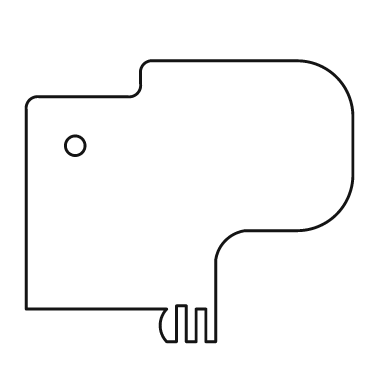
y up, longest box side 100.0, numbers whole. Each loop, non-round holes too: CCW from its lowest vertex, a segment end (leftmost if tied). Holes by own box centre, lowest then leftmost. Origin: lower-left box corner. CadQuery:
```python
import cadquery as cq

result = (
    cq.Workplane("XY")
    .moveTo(43.0, 0.0)
    .lineTo(46.0, 0.0)
    .lineTo(46.0, 11.0)
    .lineTo(49.0, 11.0)
    .lineTo(49.0, 0.0)
    .lineTo(52.0, 0.0)
    .lineTo(52.0, 10.0)
    .lineTo(55.0, 10.0)
    .lineTo(55.0, 0.0)
    .lineTo(58.0, 0.0)
    .lineTo(58.0, 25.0)
    .threePointArc((61.0, 31.0), (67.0, 34.0))
    .lineTo(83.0, 34.0)
    .threePointArc((95.0, 39.0), (100.0, 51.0))
    .lineTo(100.0, 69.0)
    .threePointArc((95.0, 81.0), (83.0, 86.0))
    .lineTo(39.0, 86.0)
    .threePointArc((36.0, 85.0), (35.0, 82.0))
    .lineTo(35.0, 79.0)
    .threePointArc((34.0, 76.0), (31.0, 75.0))
    .lineTo(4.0, 75.0)
    .threePointArc((1.0, 74.0), (0.0, 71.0))
    .lineTo(0.0, 10.0)
    .lineTo(43.0, 10.0)
    .threePointArc((41.0, 5.0), (43.0, 0.0))
    .close()
    .moveTo(15.0, 60.0)
    .circle(3.0)
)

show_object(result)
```